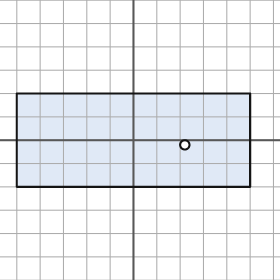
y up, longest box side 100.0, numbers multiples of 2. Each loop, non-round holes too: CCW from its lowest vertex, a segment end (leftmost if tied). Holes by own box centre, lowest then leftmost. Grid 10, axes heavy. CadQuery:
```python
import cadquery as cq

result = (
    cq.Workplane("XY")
    .moveTo(-50.0, -20.0)
    .lineTo(50.0, -20.0)
    .lineTo(50.0, 20.0)
    .lineTo(-50.0, 20.0)
    .close()
    .moveTo(22.0, -2.0)
    .circle(2.0)
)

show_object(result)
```